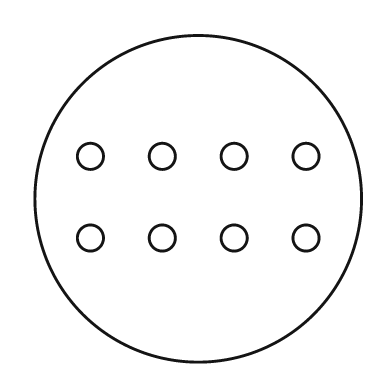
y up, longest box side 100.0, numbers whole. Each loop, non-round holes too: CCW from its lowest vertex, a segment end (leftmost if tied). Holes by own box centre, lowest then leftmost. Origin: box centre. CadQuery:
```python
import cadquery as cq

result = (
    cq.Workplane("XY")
    .moveTo(0.0, 0.0)
    .circle(50.0)
    .moveTo(-33.0, -12.0)
    .circle(4.0)
    .moveTo(-11.0, -12.0)
    .circle(4.0)
    .moveTo(11.0, -12.0)
    .circle(4.0)
    .moveTo(33.0, -12.0)
    .circle(4.0)
    .moveTo(-33.0, 13.0)
    .circle(4.0)
    .moveTo(-11.0, 13.0)
    .circle(4.0)
    .moveTo(11.0, 13.0)
    .circle(4.0)
    .moveTo(33.0, 13.0)
    .circle(4.0)
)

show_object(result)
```